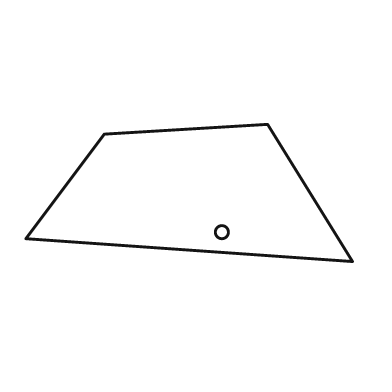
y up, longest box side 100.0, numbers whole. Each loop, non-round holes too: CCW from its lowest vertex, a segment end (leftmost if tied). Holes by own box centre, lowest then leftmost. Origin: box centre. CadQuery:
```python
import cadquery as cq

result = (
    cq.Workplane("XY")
    .moveTo(50.0, -21.0)
    .lineTo(24.0, 21.0)
    .lineTo(-26.0, 18.0)
    .lineTo(-50.0, -14.0)
    .close()
    .moveTo(10.0, -12.0)
    .circle(2.0)
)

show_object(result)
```